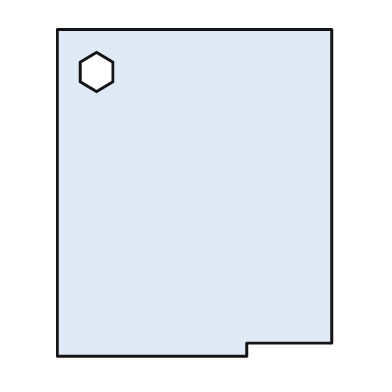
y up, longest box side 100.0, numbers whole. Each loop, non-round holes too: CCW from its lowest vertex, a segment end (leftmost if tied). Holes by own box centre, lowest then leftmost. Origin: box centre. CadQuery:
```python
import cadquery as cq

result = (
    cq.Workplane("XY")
    .moveTo(-42.0, -50.0)
    .lineTo(16.0, -50.0)
    .lineTo(16.0, -46.0)
    .lineTo(42.0, -46.0)
    .lineTo(42.0, 50.0)
    .lineTo(-42.0, 50.0)
    .close()
    .moveTo(-30.0, 31.0)
    .lineTo(-25.0, 34.0)
    .lineTo(-25.0, 40.0)
    .lineTo(-30.0, 43.0)
    .lineTo(-35.0, 40.0)
    .lineTo(-35.0, 34.0)
    .close()
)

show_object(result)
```